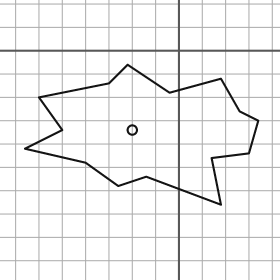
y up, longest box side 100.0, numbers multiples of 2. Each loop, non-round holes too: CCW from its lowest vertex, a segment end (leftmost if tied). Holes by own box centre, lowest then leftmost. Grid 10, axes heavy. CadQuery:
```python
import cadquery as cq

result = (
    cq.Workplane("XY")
    .moveTo(18.0, -66.0)
    .lineTo(14.0, -46.0)
    .lineTo(30.0, -44.0)
    .lineTo(34.0, -30.0)
    .lineTo(26.0, -26.0)
    .lineTo(18.0, -12.0)
    .lineTo(-4.0, -18.0)
    .lineTo(-22.0, -6.0)
    .lineTo(-30.0, -14.0)
    .lineTo(-60.0, -20.0)
    .lineTo(-50.0, -34.0)
    .lineTo(-66.0, -42.0)
    .lineTo(-40.0, -48.0)
    .lineTo(-26.0, -58.0)
    .lineTo(-14.0, -54.0)
    .close()
    .moveTo(-20.0, -34.0)
    .circle(2.0)
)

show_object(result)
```